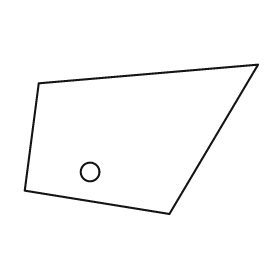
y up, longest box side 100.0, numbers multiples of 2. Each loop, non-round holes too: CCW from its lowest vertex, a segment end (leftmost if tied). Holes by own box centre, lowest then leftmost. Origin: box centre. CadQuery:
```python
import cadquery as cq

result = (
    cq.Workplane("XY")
    .moveTo(12.0, -32.0)
    .lineTo(50.0, 32.0)
    .lineTo(-44.0, 24.0)
    .lineTo(-50.0, -22.0)
    .close()
    .moveTo(-22.0, -14.0)
    .circle(4.0)
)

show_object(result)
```